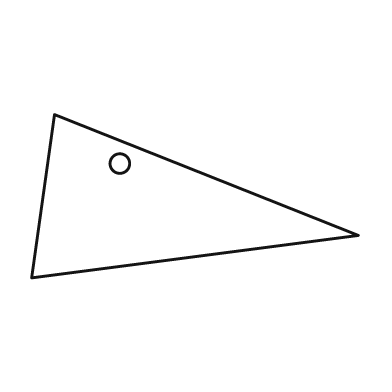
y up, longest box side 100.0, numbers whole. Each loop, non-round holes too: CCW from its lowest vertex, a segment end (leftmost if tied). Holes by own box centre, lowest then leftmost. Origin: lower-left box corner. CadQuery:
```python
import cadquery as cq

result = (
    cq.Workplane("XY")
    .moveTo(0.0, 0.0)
    .lineTo(100.0, 13.0)
    .lineTo(7.0, 50.0)
    .close()
    .moveTo(27.0, 35.0)
    .circle(3.0)
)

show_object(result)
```